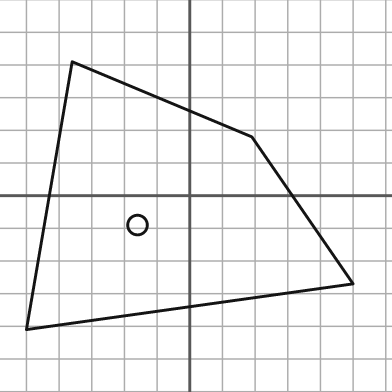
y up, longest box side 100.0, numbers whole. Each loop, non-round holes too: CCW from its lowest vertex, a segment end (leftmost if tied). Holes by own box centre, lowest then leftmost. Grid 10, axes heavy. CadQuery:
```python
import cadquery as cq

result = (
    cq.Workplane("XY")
    .moveTo(-50.0, -41.0)
    .lineTo(50.0, -27.0)
    .lineTo(19.0, 18.0)
    .lineTo(-36.0, 41.0)
    .close()
    .moveTo(-16.0, -9.0)
    .circle(3.0)
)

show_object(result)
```